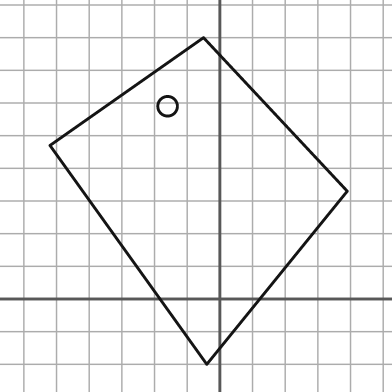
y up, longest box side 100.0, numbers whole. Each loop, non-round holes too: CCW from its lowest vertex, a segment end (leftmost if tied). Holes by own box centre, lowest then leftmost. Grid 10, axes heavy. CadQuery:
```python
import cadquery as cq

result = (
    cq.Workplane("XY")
    .moveTo(-4.0, -20.0)
    .lineTo(39.0, 33.0)
    .lineTo(-5.0, 80.0)
    .lineTo(-52.0, 47.0)
    .close()
    .moveTo(-16.0, 59.0)
    .circle(3.0)
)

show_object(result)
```